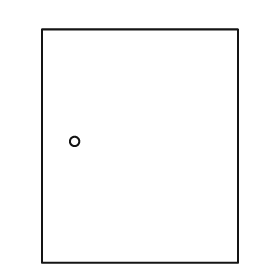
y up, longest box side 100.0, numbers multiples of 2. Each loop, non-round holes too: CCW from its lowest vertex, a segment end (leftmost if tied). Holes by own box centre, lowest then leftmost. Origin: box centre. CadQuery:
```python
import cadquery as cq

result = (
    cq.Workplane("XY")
    .moveTo(-42.0, -50.0)
    .lineTo(42.0, -50.0)
    .lineTo(42.0, 50.0)
    .lineTo(-42.0, 50.0)
    .close()
    .moveTo(-28.0, 2.0)
    .circle(2.0)
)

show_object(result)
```